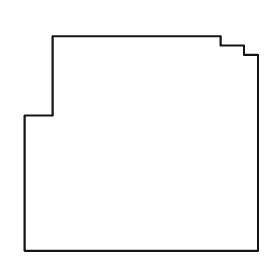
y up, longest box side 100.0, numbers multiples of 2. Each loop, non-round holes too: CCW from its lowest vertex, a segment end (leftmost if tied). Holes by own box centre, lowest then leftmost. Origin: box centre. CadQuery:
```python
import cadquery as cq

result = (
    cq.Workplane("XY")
    .moveTo(-50.0, -46.0)
    .lineTo(50.0, -46.0)
    .lineTo(50.0, 38.0)
    .lineTo(44.0, 38.0)
    .lineTo(44.0, 42.0)
    .lineTo(34.0, 42.0)
    .lineTo(34.0, 46.0)
    .lineTo(-38.0, 46.0)
    .lineTo(-38.0, 12.0)
    .lineTo(-50.0, 12.0)
    .close()
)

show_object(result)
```